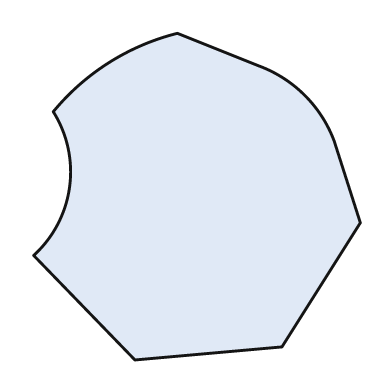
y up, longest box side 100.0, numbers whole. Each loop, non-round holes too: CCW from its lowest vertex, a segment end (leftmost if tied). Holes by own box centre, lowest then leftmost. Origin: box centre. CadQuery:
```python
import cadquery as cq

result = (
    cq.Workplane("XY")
    .moveTo(-19.0, -50.0)
    .lineTo(26.0, -46.0)
    .lineTo(50.0, -8.0)
    .lineTo(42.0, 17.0)
    .threePointArc((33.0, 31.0), (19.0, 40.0))
    .lineTo(-6.0, 50.0)
    .threePointArc((-27.0, 41.0), (-44.0, 26.0))
    .threePointArc((-39.0, 3.0), (-50.0, -18.0))
    .close()
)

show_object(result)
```